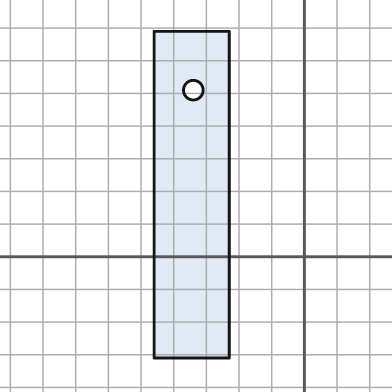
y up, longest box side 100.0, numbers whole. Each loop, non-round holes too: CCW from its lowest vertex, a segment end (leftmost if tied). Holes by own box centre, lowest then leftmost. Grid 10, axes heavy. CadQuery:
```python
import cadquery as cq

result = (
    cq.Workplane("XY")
    .moveTo(-46.0, -31.0)
    .lineTo(-23.0, -31.0)
    .lineTo(-23.0, 69.0)
    .lineTo(-46.0, 69.0)
    .close()
    .moveTo(-34.0, 51.0)
    .circle(3.0)
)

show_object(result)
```